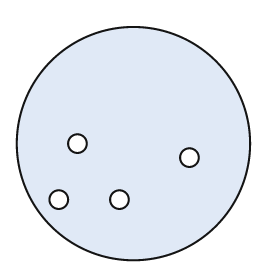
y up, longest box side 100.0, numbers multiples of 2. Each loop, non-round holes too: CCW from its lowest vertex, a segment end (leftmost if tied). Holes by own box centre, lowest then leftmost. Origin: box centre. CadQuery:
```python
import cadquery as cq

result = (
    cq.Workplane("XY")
    .moveTo(0.0, 0.0)
    .circle(50.0)
    .moveTo(-32.0, -24.0)
    .circle(4.0)
    .moveTo(-6.0, -24.0)
    .circle(4.0)
    .moveTo(24.0, -6.0)
    .circle(4.0)
    .moveTo(-24.0, 0.0)
    .circle(4.0)
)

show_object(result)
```